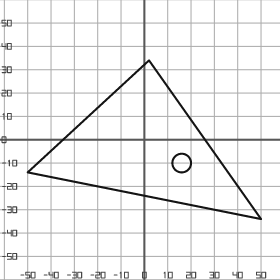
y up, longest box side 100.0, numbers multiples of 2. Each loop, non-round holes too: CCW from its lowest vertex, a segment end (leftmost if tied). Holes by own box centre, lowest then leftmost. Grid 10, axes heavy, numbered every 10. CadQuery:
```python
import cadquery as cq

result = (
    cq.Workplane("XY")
    .moveTo(50.0, -34.0)
    .lineTo(2.0, 34.0)
    .lineTo(-50.0, -14.0)
    .close()
    .moveTo(16.0, -10.0)
    .circle(4.0)
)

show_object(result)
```